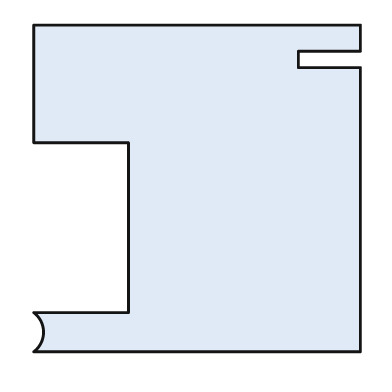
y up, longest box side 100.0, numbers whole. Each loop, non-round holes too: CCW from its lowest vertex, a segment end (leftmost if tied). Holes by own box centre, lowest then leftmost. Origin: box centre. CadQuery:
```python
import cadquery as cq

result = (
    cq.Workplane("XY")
    .moveTo(-50.0, -50.0)
    .lineTo(50.0, -50.0)
    .lineTo(50.0, 37.0)
    .lineTo(31.0, 37.0)
    .lineTo(31.0, 42.0)
    .lineTo(50.0, 42.0)
    .lineTo(50.0, 50.0)
    .lineTo(-50.0, 50.0)
    .lineTo(-50.0, 14.0)
    .lineTo(-21.0, 14.0)
    .lineTo(-21.0, -38.0)
    .lineTo(-50.0, -38.0)
    .threePointArc((-47.0, -44.0), (-50.0, -50.0))
    .close()
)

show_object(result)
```